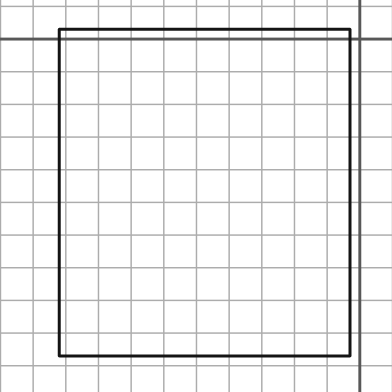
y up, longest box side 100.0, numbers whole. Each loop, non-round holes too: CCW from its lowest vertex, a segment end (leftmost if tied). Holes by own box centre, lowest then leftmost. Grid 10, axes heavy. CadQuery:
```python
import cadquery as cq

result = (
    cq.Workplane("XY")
    .moveTo(-92.0, -97.0)
    .lineTo(-3.0, -97.0)
    .lineTo(-3.0, 3.0)
    .lineTo(-92.0, 3.0)
    .close()
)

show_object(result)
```